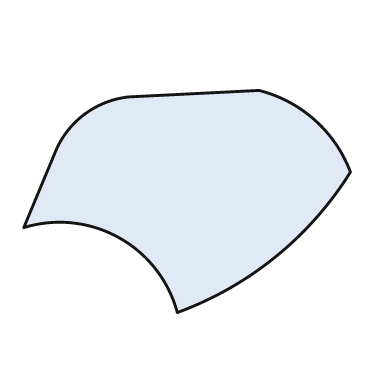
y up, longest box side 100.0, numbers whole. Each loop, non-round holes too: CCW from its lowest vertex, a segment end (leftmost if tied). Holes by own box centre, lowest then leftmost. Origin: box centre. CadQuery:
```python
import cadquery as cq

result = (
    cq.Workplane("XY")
    .moveTo(-3.0, -34.0)
    .threePointArc((27.0, -17.0), (50.0, 9.0))
    .threePointArc((39.0, 25.0), (22.0, 34.0))
    .lineTo(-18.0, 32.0)
    .threePointArc((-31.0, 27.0), (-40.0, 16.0))
    .lineTo(-50.0, -8.0)
    .threePointArc((-21.0, -11.0), (-3.0, -34.0))
    .close()
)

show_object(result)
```